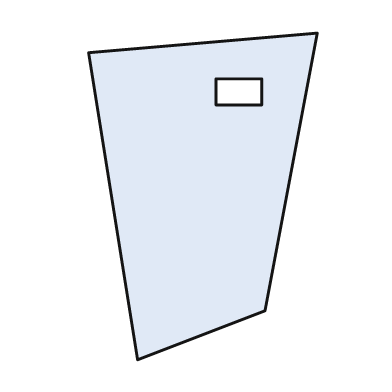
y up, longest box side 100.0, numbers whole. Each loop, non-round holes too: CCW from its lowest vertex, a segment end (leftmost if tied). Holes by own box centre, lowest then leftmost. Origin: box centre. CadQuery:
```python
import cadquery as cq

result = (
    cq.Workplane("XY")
    .moveTo(-20.0, -50.0)
    .lineTo(19.0, -35.0)
    .lineTo(35.0, 50.0)
    .lineTo(-35.0, 44.0)
    .close()
    .moveTo(4.0, 28.0)
    .lineTo(18.0, 28.0)
    .lineTo(18.0, 36.0)
    .lineTo(4.0, 36.0)
    .close()
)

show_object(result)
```